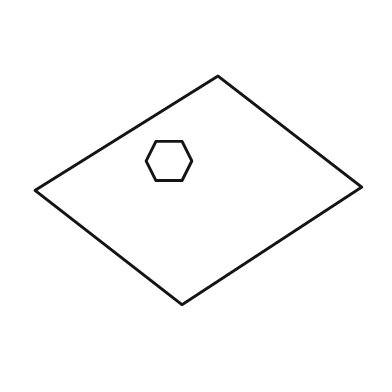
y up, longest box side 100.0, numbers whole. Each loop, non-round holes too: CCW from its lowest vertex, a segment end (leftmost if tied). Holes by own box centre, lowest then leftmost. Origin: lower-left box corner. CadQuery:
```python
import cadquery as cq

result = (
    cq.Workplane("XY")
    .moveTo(45.0, 0.0)
    .lineTo(100.0, 36.0)
    .lineTo(56.0, 70.0)
    .lineTo(0.0, 35.0)
    .close()
    .moveTo(37.0, 38.0)
    .lineTo(45.0, 38.0)
    .lineTo(48.0, 44.0)
    .lineTo(45.0, 50.0)
    .lineTo(37.0, 50.0)
    .lineTo(34.0, 44.0)
    .close()
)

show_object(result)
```